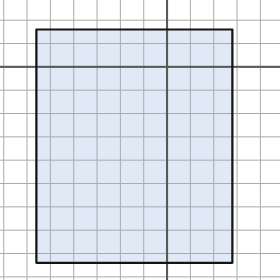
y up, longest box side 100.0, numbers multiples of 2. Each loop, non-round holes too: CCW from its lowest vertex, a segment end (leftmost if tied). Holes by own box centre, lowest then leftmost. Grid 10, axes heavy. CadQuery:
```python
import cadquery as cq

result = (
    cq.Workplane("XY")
    .moveTo(-56.0, -84.0)
    .lineTo(28.0, -84.0)
    .lineTo(28.0, 16.0)
    .lineTo(-56.0, 16.0)
    .close()
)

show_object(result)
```